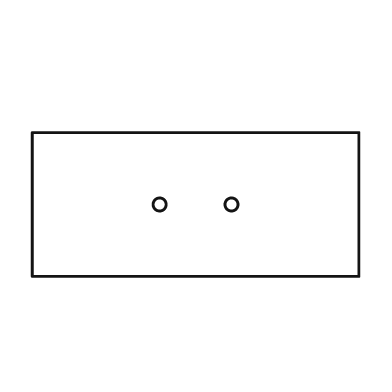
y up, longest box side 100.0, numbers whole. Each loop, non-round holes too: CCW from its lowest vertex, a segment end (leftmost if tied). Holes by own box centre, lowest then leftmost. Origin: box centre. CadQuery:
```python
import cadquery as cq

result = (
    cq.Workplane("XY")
    .moveTo(-50.0, -22.0)
    .lineTo(50.0, -22.0)
    .lineTo(50.0, 22.0)
    .lineTo(-50.0, 22.0)
    .close()
    .moveTo(-11.0, 0.0)
    .circle(2.0)
    .moveTo(11.0, 0.0)
    .circle(2.0)
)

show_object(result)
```